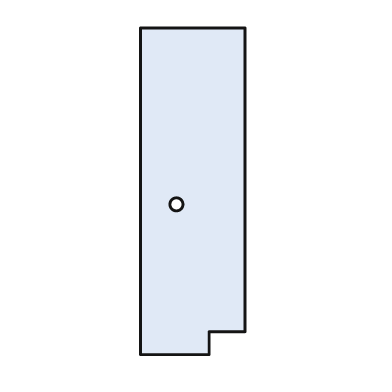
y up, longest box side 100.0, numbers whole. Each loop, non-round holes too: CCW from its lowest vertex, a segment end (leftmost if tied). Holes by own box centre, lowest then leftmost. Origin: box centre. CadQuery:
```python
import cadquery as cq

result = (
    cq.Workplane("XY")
    .moveTo(-16.0, -50.0)
    .lineTo(5.0, -50.0)
    .lineTo(5.0, -43.0)
    .lineTo(16.0, -43.0)
    .lineTo(16.0, 50.0)
    .lineTo(-16.0, 50.0)
    .close()
    .moveTo(-5.0, -4.0)
    .circle(2.0)
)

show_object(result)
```